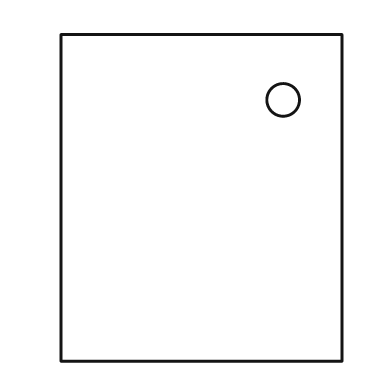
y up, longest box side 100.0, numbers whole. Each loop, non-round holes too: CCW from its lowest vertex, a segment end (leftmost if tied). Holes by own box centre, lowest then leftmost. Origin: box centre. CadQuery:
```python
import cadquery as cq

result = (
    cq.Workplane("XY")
    .moveTo(-43.0, -50.0)
    .lineTo(43.0, -50.0)
    .lineTo(43.0, 50.0)
    .lineTo(-43.0, 50.0)
    .close()
    .moveTo(25.0, 30.0)
    .circle(5.0)
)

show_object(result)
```